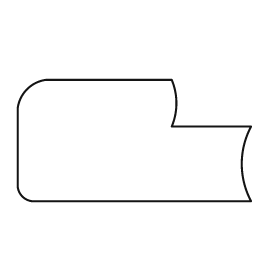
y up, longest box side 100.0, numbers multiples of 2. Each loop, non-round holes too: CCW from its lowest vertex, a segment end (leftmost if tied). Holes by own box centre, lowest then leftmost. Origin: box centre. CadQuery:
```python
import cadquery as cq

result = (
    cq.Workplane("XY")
    .moveTo(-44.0, -26.0)
    .lineTo(50.0, -26.0)
    .threePointArc((46.0, -10.0), (50.0, 6.0))
    .lineTo(16.0, 6.0)
    .threePointArc((18.0, 16.0), (16.0, 26.0))
    .lineTo(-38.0, 26.0)
    .threePointArc((-46.0, 22.0), (-50.0, 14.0))
    .lineTo(-50.0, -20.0)
    .threePointArc((-48.0, -24.0), (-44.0, -26.0))
    .close()
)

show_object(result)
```